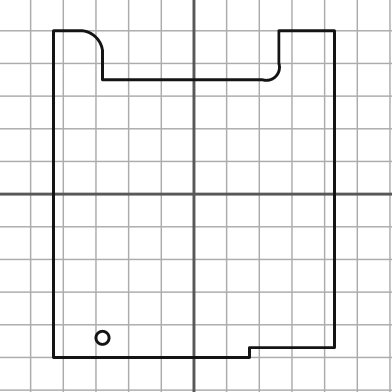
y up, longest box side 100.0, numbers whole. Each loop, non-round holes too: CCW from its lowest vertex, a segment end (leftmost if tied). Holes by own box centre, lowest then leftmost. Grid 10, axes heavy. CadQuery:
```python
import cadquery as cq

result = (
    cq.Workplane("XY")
    .moveTo(-43.0, -50.0)
    .lineTo(17.0, -50.0)
    .lineTo(17.0, -47.0)
    .lineTo(43.0, -47.0)
    .lineTo(43.0, 50.0)
    .lineTo(26.0, 50.0)
    .lineTo(26.0, 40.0)
    .threePointArc((25.0, 36.0), (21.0, 35.0))
    .lineTo(-28.0, 35.0)
    .lineTo(-28.0, 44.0)
    .threePointArc((-30.0, 48.0), (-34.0, 50.0))
    .lineTo(-43.0, 50.0)
    .close()
    .moveTo(-28.0, -44.0)
    .circle(2.0)
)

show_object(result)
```